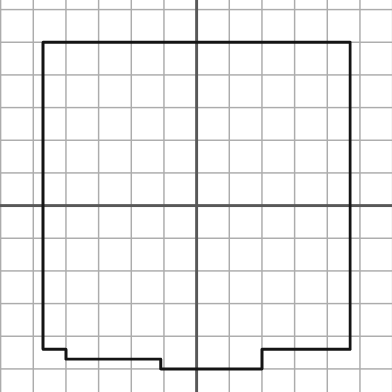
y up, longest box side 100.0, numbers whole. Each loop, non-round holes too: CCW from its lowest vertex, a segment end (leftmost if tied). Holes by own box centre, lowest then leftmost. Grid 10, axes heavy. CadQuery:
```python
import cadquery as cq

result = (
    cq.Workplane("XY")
    .moveTo(-11.0, -50.0)
    .lineTo(20.0, -50.0)
    .lineTo(20.0, -44.0)
    .lineTo(47.0, -44.0)
    .lineTo(47.0, 50.0)
    .lineTo(-47.0, 50.0)
    .lineTo(-47.0, -44.0)
    .lineTo(-40.0, -44.0)
    .lineTo(-40.0, -47.0)
    .lineTo(-11.0, -47.0)
    .close()
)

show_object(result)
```